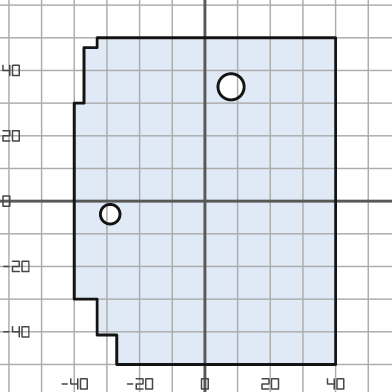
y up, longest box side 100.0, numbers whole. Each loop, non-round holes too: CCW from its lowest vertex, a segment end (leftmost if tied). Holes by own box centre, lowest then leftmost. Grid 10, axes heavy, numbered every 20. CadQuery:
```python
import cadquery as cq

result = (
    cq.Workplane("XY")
    .moveTo(-27.0, -50.0)
    .lineTo(40.0, -50.0)
    .lineTo(40.0, 50.0)
    .lineTo(-33.0, 50.0)
    .lineTo(-33.0, 47.0)
    .lineTo(-37.0, 47.0)
    .lineTo(-37.0, 30.0)
    .lineTo(-40.0, 30.0)
    .lineTo(-40.0, -30.0)
    .lineTo(-33.0, -30.0)
    .lineTo(-33.0, -41.0)
    .lineTo(-27.0, -41.0)
    .close()
    .moveTo(-29.0, -4.0)
    .circle(3.0)
    .moveTo(8.0, 35.0)
    .circle(4.0)
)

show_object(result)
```